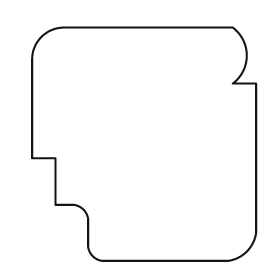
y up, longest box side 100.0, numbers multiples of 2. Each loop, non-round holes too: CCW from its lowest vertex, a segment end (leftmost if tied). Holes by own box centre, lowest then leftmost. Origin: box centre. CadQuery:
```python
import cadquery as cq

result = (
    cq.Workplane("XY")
    .moveTo(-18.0, -50.0)
    .lineTo(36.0, -50.0)
    .threePointArc((44.0, -46.0), (48.0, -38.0))
    .lineTo(48.0, 26.0)
    .lineTo(38.0, 26.0)
    .threePointArc((44.0, 38.0), (38.0, 50.0))
    .lineTo(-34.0, 50.0)
    .threePointArc((-44.0, 46.0), (-48.0, 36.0))
    .lineTo(-48.0, -6.0)
    .lineTo(-38.0, -6.0)
    .lineTo(-38.0, -26.0)
    .lineTo(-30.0, -26.0)
    .threePointArc((-26.0, -28.0), (-24.0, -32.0))
    .lineTo(-24.0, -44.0)
    .threePointArc((-22.0, -48.0), (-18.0, -50.0))
    .close()
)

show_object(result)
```